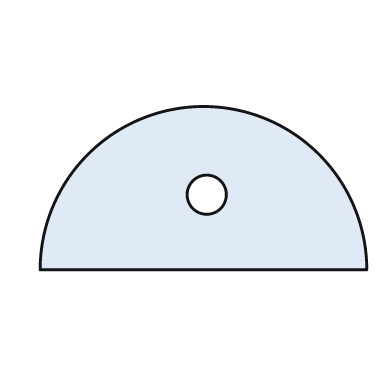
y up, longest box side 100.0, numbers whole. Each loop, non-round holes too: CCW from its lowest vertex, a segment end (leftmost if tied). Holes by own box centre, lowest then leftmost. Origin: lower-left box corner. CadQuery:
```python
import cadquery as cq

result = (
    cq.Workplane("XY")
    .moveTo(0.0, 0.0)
    .lineTo(100.0, 0.0)
    .threePointArc((50.0, 50.0), (0.0, 0.0))
    .close()
    .moveTo(51.0, 23.0)
    .circle(6.0)
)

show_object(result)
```